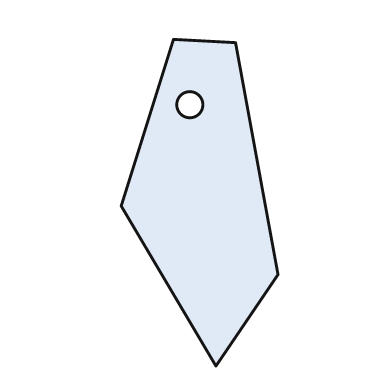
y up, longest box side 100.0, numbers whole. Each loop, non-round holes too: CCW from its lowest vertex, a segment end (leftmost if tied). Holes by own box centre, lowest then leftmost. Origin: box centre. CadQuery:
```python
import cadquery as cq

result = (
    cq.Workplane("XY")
    .moveTo(5.0, -50.0)
    .lineTo(24.0, -22.0)
    .lineTo(11.0, 49.0)
    .lineTo(-8.0, 50.0)
    .lineTo(-24.0, -1.0)
    .close()
    .moveTo(-3.0, 30.0)
    .circle(4.0)
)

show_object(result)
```